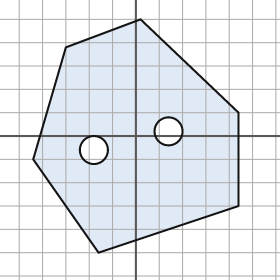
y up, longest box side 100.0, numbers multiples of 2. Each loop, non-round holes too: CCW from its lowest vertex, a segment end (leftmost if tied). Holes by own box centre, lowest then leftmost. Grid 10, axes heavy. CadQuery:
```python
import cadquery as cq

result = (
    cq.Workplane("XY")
    .moveTo(-16.0, -50.0)
    .lineTo(44.0, -30.0)
    .lineTo(44.0, 10.0)
    .lineTo(2.0, 50.0)
    .lineTo(-30.0, 38.0)
    .lineTo(-44.0, -10.0)
    .close()
    .moveTo(-18.0, -6.0)
    .circle(6.0)
    .moveTo(14.0, 2.0)
    .circle(6.0)
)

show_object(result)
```